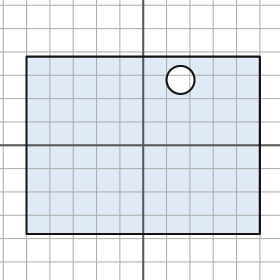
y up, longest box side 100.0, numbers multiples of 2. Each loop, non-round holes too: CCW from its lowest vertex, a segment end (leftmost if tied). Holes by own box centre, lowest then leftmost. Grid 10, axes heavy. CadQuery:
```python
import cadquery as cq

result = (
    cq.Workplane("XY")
    .moveTo(-50.0, -38.0)
    .lineTo(50.0, -38.0)
    .lineTo(50.0, 38.0)
    .lineTo(-50.0, 38.0)
    .close()
    .moveTo(16.0, 28.0)
    .circle(6.0)
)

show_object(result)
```